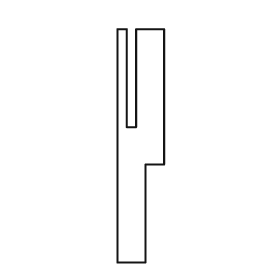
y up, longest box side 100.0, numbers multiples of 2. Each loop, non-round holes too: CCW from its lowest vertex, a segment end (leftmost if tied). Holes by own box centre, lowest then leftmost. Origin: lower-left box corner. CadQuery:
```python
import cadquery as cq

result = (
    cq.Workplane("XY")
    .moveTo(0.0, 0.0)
    .lineTo(12.0, 0.0)
    .lineTo(12.0, 42.0)
    .lineTo(20.0, 42.0)
    .lineTo(20.0, 100.0)
    .lineTo(8.0, 100.0)
    .lineTo(8.0, 58.0)
    .lineTo(4.0, 58.0)
    .lineTo(4.0, 100.0)
    .lineTo(0.0, 100.0)
    .close()
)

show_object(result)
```